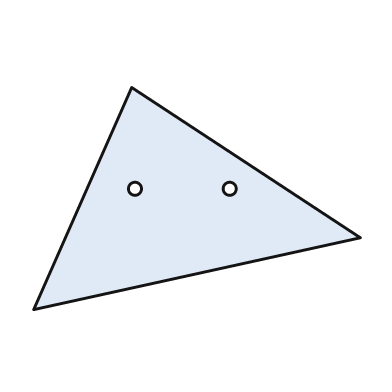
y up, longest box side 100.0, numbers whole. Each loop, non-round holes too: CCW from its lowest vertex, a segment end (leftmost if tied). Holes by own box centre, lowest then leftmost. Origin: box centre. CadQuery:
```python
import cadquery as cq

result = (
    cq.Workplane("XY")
    .moveTo(-50.0, -34.0)
    .lineTo(50.0, -12.0)
    .lineTo(-20.0, 34.0)
    .close()
    .moveTo(-19.0, 3.0)
    .circle(2.0)
    .moveTo(10.0, 3.0)
    .circle(2.0)
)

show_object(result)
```